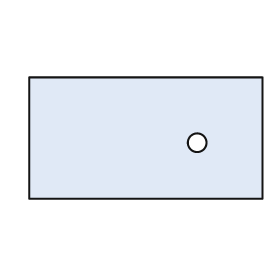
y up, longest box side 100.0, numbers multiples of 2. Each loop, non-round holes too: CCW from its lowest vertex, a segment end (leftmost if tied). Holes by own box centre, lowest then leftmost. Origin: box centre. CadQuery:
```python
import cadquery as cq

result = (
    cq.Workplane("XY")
    .moveTo(-50.0, -26.0)
    .lineTo(50.0, -26.0)
    .lineTo(50.0, 26.0)
    .lineTo(-50.0, 26.0)
    .close()
    .moveTo(22.0, -2.0)
    .circle(4.0)
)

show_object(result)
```